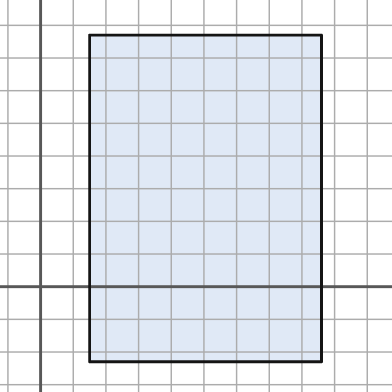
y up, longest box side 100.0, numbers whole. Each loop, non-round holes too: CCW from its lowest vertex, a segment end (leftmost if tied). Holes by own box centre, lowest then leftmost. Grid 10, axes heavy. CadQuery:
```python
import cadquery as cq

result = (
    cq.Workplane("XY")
    .moveTo(15.0, -23.0)
    .lineTo(86.0, -23.0)
    .lineTo(86.0, 77.0)
    .lineTo(15.0, 77.0)
    .close()
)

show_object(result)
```